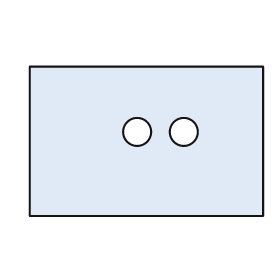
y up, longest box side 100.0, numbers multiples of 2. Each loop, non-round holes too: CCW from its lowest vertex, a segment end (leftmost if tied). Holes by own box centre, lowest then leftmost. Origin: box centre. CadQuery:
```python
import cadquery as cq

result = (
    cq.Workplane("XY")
    .moveTo(-50.0, -32.0)
    .lineTo(50.0, -32.0)
    .lineTo(50.0, 32.0)
    .lineTo(-50.0, 32.0)
    .close()
    .moveTo(-4.0, 4.0)
    .circle(6.0)
    .moveTo(16.0, 4.0)
    .circle(6.0)
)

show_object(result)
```